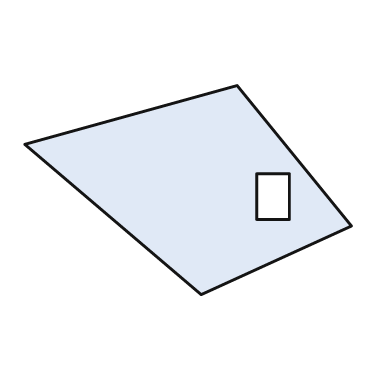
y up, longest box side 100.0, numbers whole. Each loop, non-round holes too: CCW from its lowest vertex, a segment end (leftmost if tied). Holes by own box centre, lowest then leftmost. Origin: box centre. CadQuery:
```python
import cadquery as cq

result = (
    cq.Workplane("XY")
    .moveTo(4.0, -32.0)
    .lineTo(50.0, -11.0)
    .lineTo(15.0, 32.0)
    .lineTo(-50.0, 14.0)
    .close()
    .moveTo(21.0, -9.0)
    .lineTo(31.0, -9.0)
    .lineTo(31.0, 5.0)
    .lineTo(21.0, 5.0)
    .close()
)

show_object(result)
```